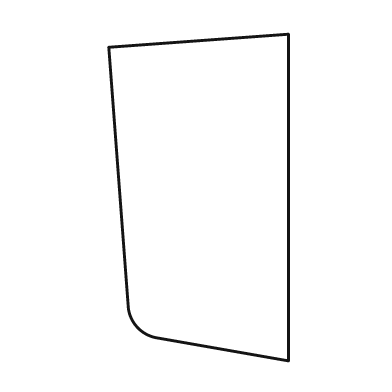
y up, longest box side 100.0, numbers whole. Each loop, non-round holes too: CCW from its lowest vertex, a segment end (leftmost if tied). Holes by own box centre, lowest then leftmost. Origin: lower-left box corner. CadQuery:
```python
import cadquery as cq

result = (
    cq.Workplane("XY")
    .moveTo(55.0, 0.0)
    .lineTo(55.0, 100.0)
    .lineTo(0.0, 96.0)
    .lineTo(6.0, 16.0)
    .threePointArc((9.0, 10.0), (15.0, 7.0))
    .close()
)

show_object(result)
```